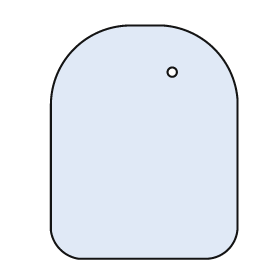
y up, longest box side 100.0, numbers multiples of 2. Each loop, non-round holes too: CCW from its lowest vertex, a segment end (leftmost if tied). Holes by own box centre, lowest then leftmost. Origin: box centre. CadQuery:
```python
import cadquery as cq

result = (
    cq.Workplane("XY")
    .moveTo(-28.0, -50.0)
    .lineTo(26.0, -50.0)
    .threePointArc((36.0, -46.0), (40.0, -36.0))
    .lineTo(40.0, 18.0)
    .threePointArc((30.0, 40.0), (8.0, 50.0))
    .lineTo(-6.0, 50.0)
    .threePointArc((-30.0, 40.0), (-40.0, 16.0))
    .lineTo(-40.0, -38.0)
    .threePointArc((-36.0, -46.0), (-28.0, -50.0))
    .close()
    .moveTo(12.0, 30.0)
    .circle(2.0)
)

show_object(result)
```